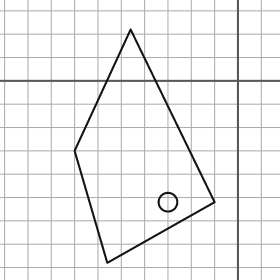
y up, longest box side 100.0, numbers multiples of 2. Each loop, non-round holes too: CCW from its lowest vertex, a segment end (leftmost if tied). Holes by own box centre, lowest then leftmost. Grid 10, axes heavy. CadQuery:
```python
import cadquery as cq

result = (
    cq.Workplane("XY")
    .moveTo(-56.0, -78.0)
    .lineTo(-10.0, -52.0)
    .lineTo(-46.0, 22.0)
    .lineTo(-70.0, -30.0)
    .close()
    .moveTo(-30.0, -52.0)
    .circle(4.0)
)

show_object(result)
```